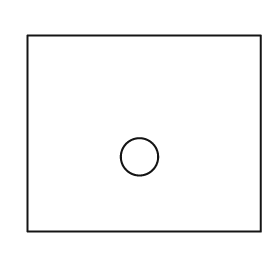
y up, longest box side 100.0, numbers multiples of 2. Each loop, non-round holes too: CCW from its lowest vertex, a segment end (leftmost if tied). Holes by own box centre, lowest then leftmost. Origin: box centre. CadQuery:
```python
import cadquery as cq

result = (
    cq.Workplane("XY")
    .moveTo(-50.0, -42.0)
    .lineTo(50.0, -42.0)
    .lineTo(50.0, 42.0)
    .lineTo(-50.0, 42.0)
    .close()
    .moveTo(-2.0, -10.0)
    .circle(8.0)
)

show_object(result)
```